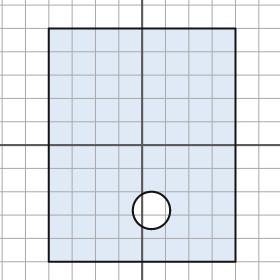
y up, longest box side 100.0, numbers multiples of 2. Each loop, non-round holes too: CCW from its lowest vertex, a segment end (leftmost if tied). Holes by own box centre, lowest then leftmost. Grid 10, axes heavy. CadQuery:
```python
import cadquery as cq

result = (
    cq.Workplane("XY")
    .moveTo(-40.0, -50.0)
    .lineTo(40.0, -50.0)
    .lineTo(40.0, 50.0)
    .lineTo(-40.0, 50.0)
    .close()
    .moveTo(4.0, -28.0)
    .circle(8.0)
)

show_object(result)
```